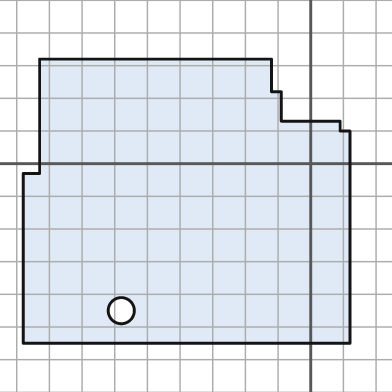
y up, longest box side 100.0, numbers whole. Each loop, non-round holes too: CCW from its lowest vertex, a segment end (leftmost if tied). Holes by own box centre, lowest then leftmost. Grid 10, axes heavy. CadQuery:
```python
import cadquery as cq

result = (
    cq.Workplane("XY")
    .moveTo(-88.0, -55.0)
    .lineTo(12.0, -55.0)
    .lineTo(12.0, 10.0)
    .lineTo(9.0, 10.0)
    .lineTo(9.0, 13.0)
    .lineTo(-9.0, 13.0)
    .lineTo(-9.0, 22.0)
    .lineTo(-12.0, 22.0)
    .lineTo(-12.0, 32.0)
    .lineTo(-83.0, 32.0)
    .lineTo(-83.0, -3.0)
    .lineTo(-88.0, -3.0)
    .close()
    .moveTo(-58.0, -45.0)
    .circle(4.0)
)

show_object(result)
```